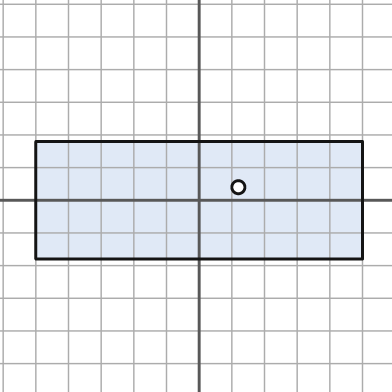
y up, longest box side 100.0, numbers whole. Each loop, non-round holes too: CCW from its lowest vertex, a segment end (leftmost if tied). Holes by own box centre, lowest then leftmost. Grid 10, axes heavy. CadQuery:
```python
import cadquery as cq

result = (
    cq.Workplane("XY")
    .moveTo(-50.0, -18.0)
    .lineTo(50.0, -18.0)
    .lineTo(50.0, 18.0)
    .lineTo(-50.0, 18.0)
    .close()
    .moveTo(12.0, 4.0)
    .circle(2.0)
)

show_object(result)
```